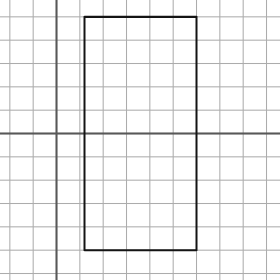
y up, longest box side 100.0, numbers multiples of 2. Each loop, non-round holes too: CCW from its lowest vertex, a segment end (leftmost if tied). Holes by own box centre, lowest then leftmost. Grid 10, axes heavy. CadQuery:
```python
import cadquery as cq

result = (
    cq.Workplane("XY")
    .moveTo(12.0, -50.0)
    .lineTo(60.0, -50.0)
    .lineTo(60.0, 50.0)
    .lineTo(12.0, 50.0)
    .close()
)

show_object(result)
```